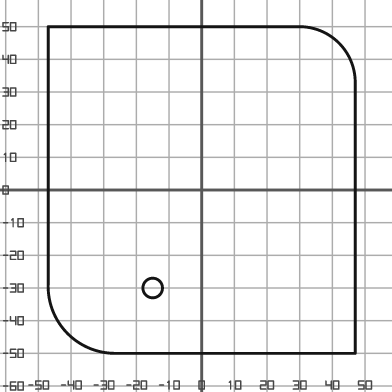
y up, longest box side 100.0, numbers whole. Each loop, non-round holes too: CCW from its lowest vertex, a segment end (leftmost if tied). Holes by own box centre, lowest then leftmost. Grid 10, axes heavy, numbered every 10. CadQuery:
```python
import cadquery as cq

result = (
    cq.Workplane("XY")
    .moveTo(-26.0, -50.0)
    .lineTo(47.0, -50.0)
    .lineTo(47.0, 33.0)
    .threePointArc((42.0, 45.0), (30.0, 50.0))
    .lineTo(-47.0, 50.0)
    .lineTo(-47.0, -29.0)
    .threePointArc((-41.0, -44.0), (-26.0, -50.0))
    .close()
    .moveTo(-15.0, -30.0)
    .circle(3.0)
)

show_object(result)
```